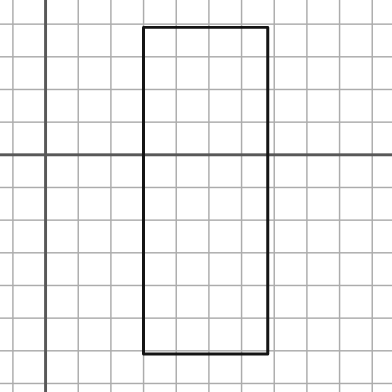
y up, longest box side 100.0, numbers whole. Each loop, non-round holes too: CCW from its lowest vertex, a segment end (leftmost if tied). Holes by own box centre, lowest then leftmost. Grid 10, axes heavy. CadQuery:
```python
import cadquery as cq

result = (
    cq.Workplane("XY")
    .moveTo(30.0, -61.0)
    .lineTo(68.0, -61.0)
    .lineTo(68.0, 39.0)
    .lineTo(30.0, 39.0)
    .close()
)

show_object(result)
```